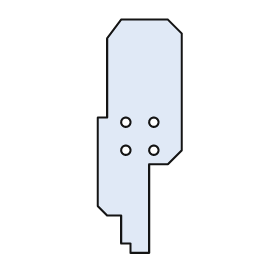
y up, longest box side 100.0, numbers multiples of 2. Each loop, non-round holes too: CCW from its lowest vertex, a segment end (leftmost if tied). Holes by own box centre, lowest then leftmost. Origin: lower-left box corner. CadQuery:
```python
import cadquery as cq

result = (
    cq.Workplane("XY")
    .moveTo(14.0, 0.0)
    .lineTo(22.0, 0.0)
    .lineTo(22.0, 38.0)
    .lineTo(30.0, 38.0)
    .lineTo(36.0, 44.0)
    .lineTo(36.0, 94.0)
    .lineTo(30.0, 100.0)
    .lineTo(10.0, 100.0)
    .lineTo(4.0, 92.0)
    .lineTo(4.0, 58.0)
    .lineTo(0.0, 58.0)
    .lineTo(0.0, 20.0)
    .lineTo(4.0, 16.0)
    .lineTo(10.0, 16.0)
    .lineTo(10.0, 4.0)
    .lineTo(14.0, 4.0)
    .close()
    .moveTo(12.0, 44.0)
    .circle(2.0)
    .moveTo(24.0, 44.0)
    .circle(2.0)
    .moveTo(12.0, 56.0)
    .circle(2.0)
    .moveTo(24.0, 56.0)
    .circle(2.0)
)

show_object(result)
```